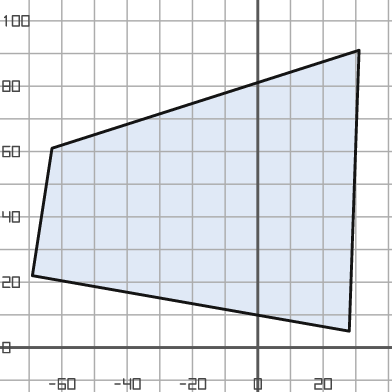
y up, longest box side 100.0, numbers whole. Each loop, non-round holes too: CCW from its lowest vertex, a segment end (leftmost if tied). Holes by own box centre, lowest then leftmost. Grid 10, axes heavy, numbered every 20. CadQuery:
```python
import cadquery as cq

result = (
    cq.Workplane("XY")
    .moveTo(28.0, 5.0)
    .lineTo(31.0, 91.0)
    .lineTo(-63.0, 61.0)
    .lineTo(-69.0, 22.0)
    .close()
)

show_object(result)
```